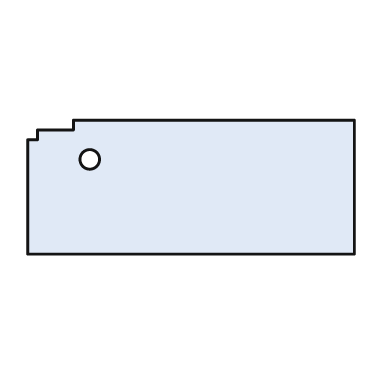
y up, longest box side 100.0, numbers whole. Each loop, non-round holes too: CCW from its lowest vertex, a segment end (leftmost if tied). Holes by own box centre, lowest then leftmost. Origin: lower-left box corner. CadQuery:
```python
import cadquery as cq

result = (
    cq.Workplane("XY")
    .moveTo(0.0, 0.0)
    .lineTo(100.0, 0.0)
    .lineTo(100.0, 41.0)
    .lineTo(14.0, 41.0)
    .lineTo(14.0, 38.0)
    .lineTo(3.0, 38.0)
    .lineTo(3.0, 35.0)
    .lineTo(0.0, 35.0)
    .close()
    .moveTo(19.0, 29.0)
    .circle(3.0)
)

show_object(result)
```